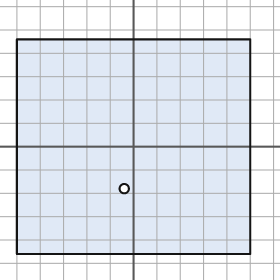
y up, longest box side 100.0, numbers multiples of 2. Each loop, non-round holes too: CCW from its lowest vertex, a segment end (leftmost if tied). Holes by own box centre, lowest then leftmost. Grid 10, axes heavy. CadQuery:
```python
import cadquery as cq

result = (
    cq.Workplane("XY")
    .moveTo(-50.0, -46.0)
    .lineTo(50.0, -46.0)
    .lineTo(50.0, 46.0)
    .lineTo(-50.0, 46.0)
    .close()
    .moveTo(-4.0, -18.0)
    .circle(2.0)
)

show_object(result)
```